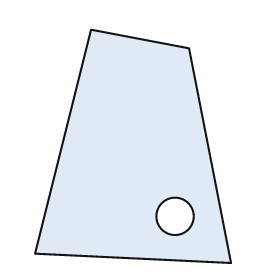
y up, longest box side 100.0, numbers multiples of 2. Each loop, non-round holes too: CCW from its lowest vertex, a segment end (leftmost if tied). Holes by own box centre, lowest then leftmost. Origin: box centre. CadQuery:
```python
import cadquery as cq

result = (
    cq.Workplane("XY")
    .moveTo(42.0, -50.0)
    .lineTo(24.0, 42.0)
    .lineTo(-18.0, 50.0)
    .lineTo(-42.0, -46.0)
    .close()
    .moveTo(18.0, -30.0)
    .circle(8.0)
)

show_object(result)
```